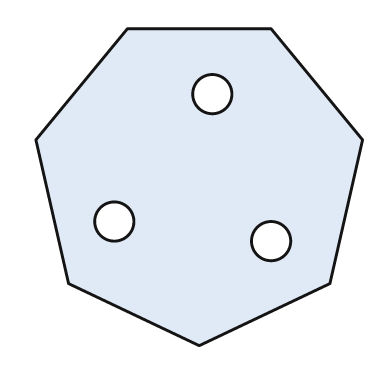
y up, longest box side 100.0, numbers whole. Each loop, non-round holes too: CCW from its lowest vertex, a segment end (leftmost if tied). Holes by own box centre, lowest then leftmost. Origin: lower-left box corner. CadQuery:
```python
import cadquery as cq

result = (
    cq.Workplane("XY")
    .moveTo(50.0, 0.0)
    .lineTo(90.0, 19.0)
    .lineTo(100.0, 63.0)
    .lineTo(72.0, 97.0)
    .lineTo(28.0, 97.0)
    .lineTo(0.0, 63.0)
    .lineTo(10.0, 19.0)
    .close()
    .moveTo(72.0, 32.0)
    .circle(6.0)
    .moveTo(24.0, 38.0)
    .circle(6.0)
    .moveTo(54.0, 77.0)
    .circle(6.0)
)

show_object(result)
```